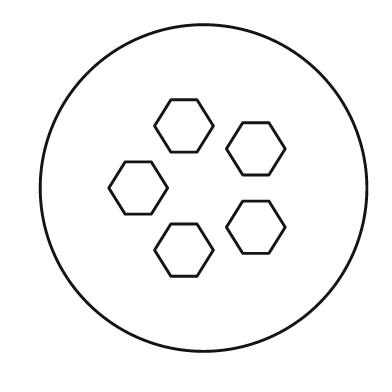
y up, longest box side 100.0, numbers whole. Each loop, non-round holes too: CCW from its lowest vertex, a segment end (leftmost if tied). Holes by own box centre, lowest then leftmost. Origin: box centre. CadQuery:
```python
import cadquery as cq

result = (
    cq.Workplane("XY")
    .moveTo(0.0, 0.0)
    .circle(50.0)
    .moveTo(-10.0, -27.0)
    .lineTo(-2.0, -27.0)
    .lineTo(3.0, -19.0)
    .lineTo(-2.0, -11.0)
    .lineTo(-10.0, -11.0)
    .lineTo(-15.0, -19.0)
    .close()
    .moveTo(12.0, -20.0)
    .lineTo(20.0, -20.0)
    .lineTo(25.0, -12.0)
    .lineTo(20.0, -4.0)
    .lineTo(12.0, -4.0)
    .lineTo(7.0, -12.0)
    .close()
    .moveTo(-24.0, -8.0)
    .lineTo(-16.0, -8.0)
    .lineTo(-11.0, 0.0)
    .lineTo(-16.0, 8.0)
    .lineTo(-24.0, 8.0)
    .lineTo(-29.0, 0.0)
    .close()
    .moveTo(12.0, 4.0)
    .lineTo(20.0, 4.0)
    .lineTo(25.0, 12.0)
    .lineTo(20.0, 20.0)
    .lineTo(12.0, 20.0)
    .lineTo(7.0, 12.0)
    .close()
    .moveTo(-10.0, 11.0)
    .lineTo(-2.0, 11.0)
    .lineTo(3.0, 19.0)
    .lineTo(-2.0, 27.0)
    .lineTo(-10.0, 27.0)
    .lineTo(-15.0, 19.0)
    .close()
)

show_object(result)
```